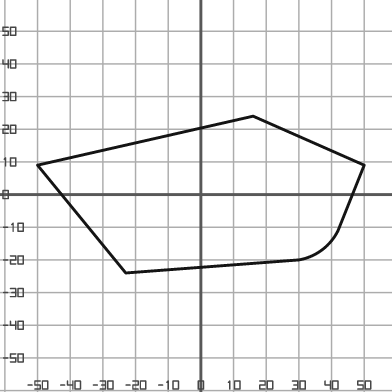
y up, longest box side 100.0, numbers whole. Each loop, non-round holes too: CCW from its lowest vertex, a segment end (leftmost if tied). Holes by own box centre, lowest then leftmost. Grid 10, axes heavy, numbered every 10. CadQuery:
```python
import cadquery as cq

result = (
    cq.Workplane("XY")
    .moveTo(-23.0, -24.0)
    .lineTo(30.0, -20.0)
    .threePointArc((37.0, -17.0), (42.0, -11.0))
    .lineTo(50.0, 9.0)
    .lineTo(16.0, 24.0)
    .lineTo(-50.0, 9.0)
    .close()
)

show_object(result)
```